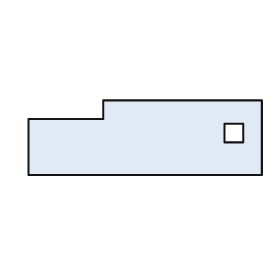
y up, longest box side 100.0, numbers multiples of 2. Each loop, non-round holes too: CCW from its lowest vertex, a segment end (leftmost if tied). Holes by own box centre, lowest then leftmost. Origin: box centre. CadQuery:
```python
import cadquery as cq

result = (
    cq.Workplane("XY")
    .moveTo(-50.0, -16.0)
    .lineTo(50.0, -16.0)
    .lineTo(50.0, 16.0)
    .lineTo(-18.0, 16.0)
    .lineTo(-18.0, 8.0)
    .lineTo(-50.0, 8.0)
    .close()
    .moveTo(34.0, -2.0)
    .lineTo(42.0, -2.0)
    .lineTo(42.0, 6.0)
    .lineTo(34.0, 6.0)
    .close()
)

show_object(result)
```